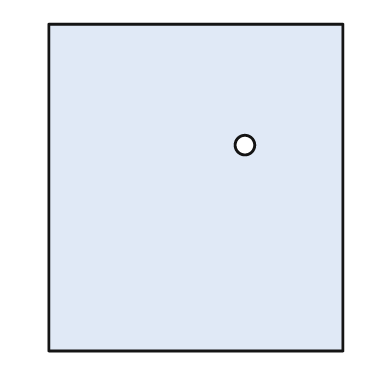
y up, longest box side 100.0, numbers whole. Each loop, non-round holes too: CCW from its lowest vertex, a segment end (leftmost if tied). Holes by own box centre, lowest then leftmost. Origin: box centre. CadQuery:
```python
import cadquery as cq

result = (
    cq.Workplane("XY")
    .moveTo(-45.0, -50.0)
    .lineTo(45.0, -50.0)
    .lineTo(45.0, 50.0)
    .lineTo(-45.0, 50.0)
    .close()
    .moveTo(15.0, 13.0)
    .circle(3.0)
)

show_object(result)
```